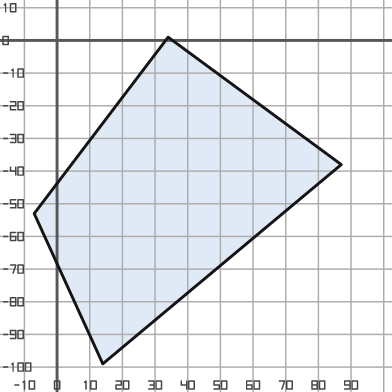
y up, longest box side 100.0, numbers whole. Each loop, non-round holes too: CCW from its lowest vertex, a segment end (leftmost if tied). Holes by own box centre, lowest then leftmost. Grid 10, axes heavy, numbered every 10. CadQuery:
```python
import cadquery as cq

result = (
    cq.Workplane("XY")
    .moveTo(14.0, -99.0)
    .lineTo(87.0, -38.0)
    .lineTo(34.0, 1.0)
    .lineTo(-7.0, -53.0)
    .close()
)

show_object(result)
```